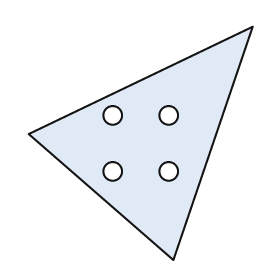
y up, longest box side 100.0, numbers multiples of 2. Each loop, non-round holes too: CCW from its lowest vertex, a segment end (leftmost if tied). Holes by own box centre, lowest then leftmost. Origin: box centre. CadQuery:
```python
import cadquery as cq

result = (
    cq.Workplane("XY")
    .moveTo(14.0, -50.0)
    .lineTo(48.0, 50.0)
    .lineTo(-48.0, 4.0)
    .close()
    .moveTo(-12.0, -12.0)
    .circle(4.0)
    .moveTo(12.0, -12.0)
    .circle(4.0)
    .moveTo(-12.0, 12.0)
    .circle(4.0)
    .moveTo(12.0, 12.0)
    .circle(4.0)
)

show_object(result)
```